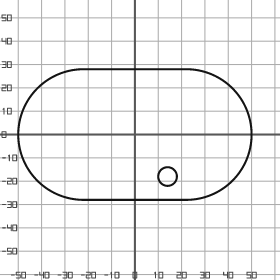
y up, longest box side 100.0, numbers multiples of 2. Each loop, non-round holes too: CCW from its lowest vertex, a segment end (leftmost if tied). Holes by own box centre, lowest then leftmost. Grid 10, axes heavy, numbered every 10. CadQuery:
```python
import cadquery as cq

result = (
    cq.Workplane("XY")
    .moveTo(-22.0, -28.0)
    .lineTo(22.0, -28.0)
    .threePointArc((50.0, 0.0), (22.0, 28.0))
    .lineTo(-22.0, 28.0)
    .threePointArc((-50.0, 0.0), (-22.0, -28.0))
    .close()
    .moveTo(14.0, -18.0)
    .circle(4.0)
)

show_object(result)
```